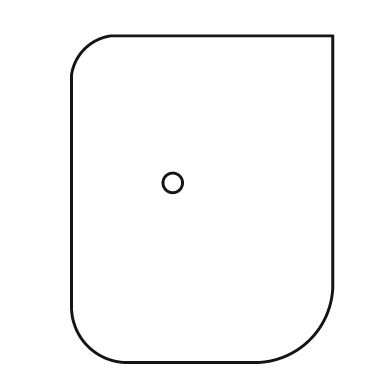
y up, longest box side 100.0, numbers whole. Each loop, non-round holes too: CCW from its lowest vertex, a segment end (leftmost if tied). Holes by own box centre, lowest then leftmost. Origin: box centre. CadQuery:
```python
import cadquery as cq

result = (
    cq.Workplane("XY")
    .moveTo(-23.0, -50.0)
    .lineTo(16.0, -50.0)
    .threePointArc((33.0, -43.0), (40.0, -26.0))
    .lineTo(40.0, 50.0)
    .lineTo(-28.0, 50.0)
    .threePointArc((-36.0, 46.0), (-40.0, 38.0))
    .lineTo(-40.0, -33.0)
    .threePointArc((-35.0, -45.0), (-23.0, -50.0))
    .close()
    .moveTo(-9.0, 5.0)
    .circle(3.0)
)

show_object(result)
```